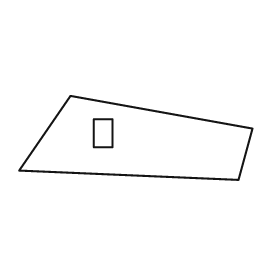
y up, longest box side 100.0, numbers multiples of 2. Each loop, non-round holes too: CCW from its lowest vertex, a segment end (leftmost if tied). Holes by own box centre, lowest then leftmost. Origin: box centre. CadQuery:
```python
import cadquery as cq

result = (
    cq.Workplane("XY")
    .moveTo(44.0, -18.0)
    .lineTo(50.0, 4.0)
    .lineTo(-28.0, 18.0)
    .lineTo(-50.0, -14.0)
    .close()
    .moveTo(-18.0, -4.0)
    .lineTo(-10.0, -4.0)
    .lineTo(-10.0, 8.0)
    .lineTo(-18.0, 8.0)
    .close()
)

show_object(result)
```